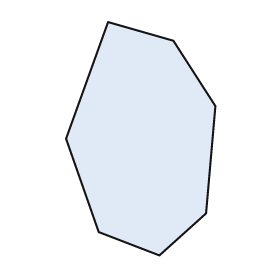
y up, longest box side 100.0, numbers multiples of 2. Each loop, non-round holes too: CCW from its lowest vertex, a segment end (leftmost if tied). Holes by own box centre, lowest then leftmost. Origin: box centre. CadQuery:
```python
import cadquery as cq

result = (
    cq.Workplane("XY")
    .moveTo(8.0, -50.0)
    .lineTo(28.0, -32.0)
    .lineTo(32.0, 14.0)
    .lineTo(14.0, 42.0)
    .lineTo(-14.0, 50.0)
    .lineTo(-32.0, 0.0)
    .lineTo(-18.0, -40.0)
    .close()
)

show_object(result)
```